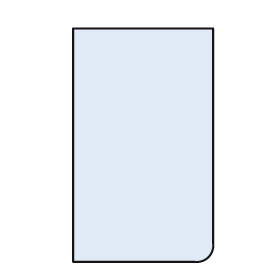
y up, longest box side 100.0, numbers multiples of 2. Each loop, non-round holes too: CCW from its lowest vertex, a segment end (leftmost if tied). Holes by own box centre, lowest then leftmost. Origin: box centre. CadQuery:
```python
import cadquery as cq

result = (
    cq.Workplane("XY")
    .moveTo(-30.0, -50.0)
    .lineTo(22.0, -50.0)
    .threePointArc((28.0, -48.0), (30.0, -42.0))
    .lineTo(30.0, 50.0)
    .lineTo(-30.0, 50.0)
    .close()
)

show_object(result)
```